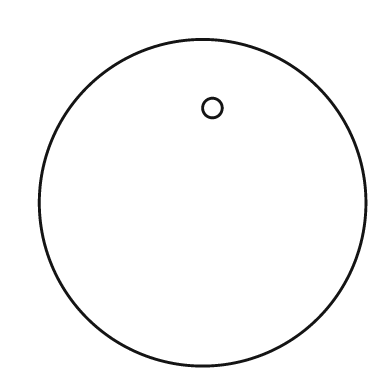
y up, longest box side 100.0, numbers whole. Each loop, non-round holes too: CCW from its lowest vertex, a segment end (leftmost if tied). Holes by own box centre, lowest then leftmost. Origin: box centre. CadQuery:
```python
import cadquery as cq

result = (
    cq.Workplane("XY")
    .moveTo(0.0, 0.0)
    .circle(50.0)
    .moveTo(3.0, 29.0)
    .circle(3.0)
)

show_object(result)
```